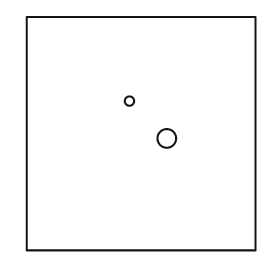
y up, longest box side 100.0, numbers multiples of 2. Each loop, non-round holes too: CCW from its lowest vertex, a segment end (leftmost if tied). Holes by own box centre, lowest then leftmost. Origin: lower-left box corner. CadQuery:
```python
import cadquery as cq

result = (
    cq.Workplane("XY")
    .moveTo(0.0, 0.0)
    .lineTo(98.0, 0.0)
    .lineTo(98.0, 100.0)
    .lineTo(0.0, 100.0)
    .close()
    .moveTo(60.0, 48.0)
    .circle(4.0)
    .moveTo(44.0, 64.0)
    .circle(2.0)
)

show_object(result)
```